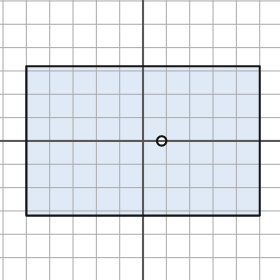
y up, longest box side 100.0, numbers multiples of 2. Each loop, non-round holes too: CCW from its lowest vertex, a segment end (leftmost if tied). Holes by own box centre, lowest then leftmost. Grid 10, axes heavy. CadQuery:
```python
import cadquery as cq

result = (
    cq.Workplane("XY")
    .moveTo(-50.0, -32.0)
    .lineTo(50.0, -32.0)
    .lineTo(50.0, 32.0)
    .lineTo(-50.0, 32.0)
    .close()
    .moveTo(8.0, 0.0)
    .circle(2.0)
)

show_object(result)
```